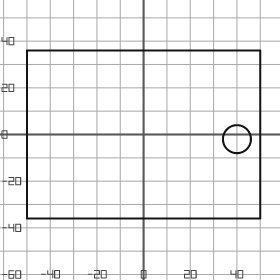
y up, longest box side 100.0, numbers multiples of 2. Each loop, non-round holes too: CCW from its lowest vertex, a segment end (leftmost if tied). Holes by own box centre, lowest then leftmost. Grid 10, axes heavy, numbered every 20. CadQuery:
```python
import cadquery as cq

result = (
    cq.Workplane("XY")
    .moveTo(-50.0, -36.0)
    .lineTo(50.0, -36.0)
    .lineTo(50.0, 36.0)
    .lineTo(-50.0, 36.0)
    .close()
    .moveTo(40.0, -2.0)
    .circle(6.0)
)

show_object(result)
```